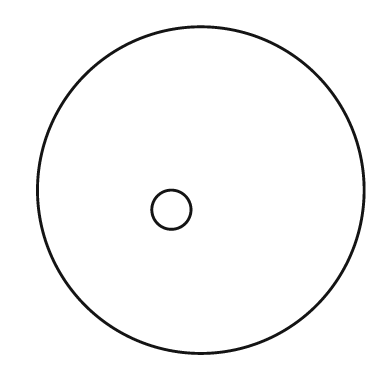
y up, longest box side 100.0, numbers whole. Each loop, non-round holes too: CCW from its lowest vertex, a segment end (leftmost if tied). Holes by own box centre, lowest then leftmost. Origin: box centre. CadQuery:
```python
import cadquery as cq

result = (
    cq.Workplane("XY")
    .moveTo(0.0, 0.0)
    .circle(50.0)
    .moveTo(-9.0, -6.0)
    .circle(6.0)
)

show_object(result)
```